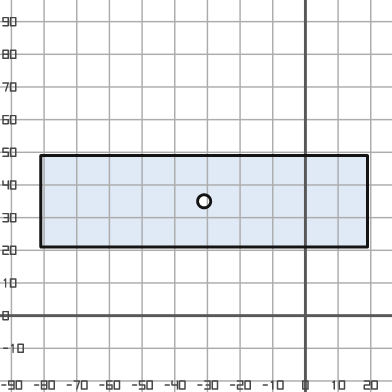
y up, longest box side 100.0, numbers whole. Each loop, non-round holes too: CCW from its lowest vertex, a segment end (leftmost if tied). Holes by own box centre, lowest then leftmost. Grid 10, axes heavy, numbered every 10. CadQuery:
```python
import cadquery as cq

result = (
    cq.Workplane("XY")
    .moveTo(-81.0, 21.0)
    .lineTo(19.0, 21.0)
    .lineTo(19.0, 49.0)
    .lineTo(-81.0, 49.0)
    .close()
    .moveTo(-31.0, 35.0)
    .circle(2.0)
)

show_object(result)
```